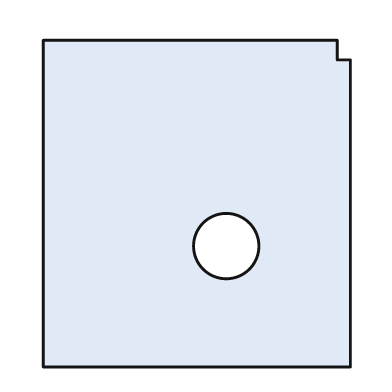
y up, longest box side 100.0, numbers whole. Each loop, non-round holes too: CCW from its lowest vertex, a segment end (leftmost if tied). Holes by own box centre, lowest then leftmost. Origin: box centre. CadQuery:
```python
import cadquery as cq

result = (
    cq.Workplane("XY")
    .moveTo(-47.0, -50.0)
    .lineTo(47.0, -50.0)
    .lineTo(47.0, 44.0)
    .lineTo(43.0, 44.0)
    .lineTo(43.0, 50.0)
    .lineTo(-47.0, 50.0)
    .close()
    .moveTo(9.0, -13.0)
    .circle(10.0)
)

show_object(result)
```